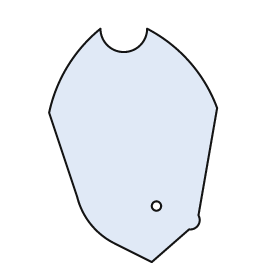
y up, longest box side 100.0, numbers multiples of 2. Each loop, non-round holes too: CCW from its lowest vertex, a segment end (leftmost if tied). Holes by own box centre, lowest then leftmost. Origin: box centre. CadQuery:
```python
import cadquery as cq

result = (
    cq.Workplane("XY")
    .moveTo(8.0, -50.0)
    .lineTo(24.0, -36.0)
    .threePointArc((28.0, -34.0), (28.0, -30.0))
    .lineTo(36.0, 16.0)
    .threePointArc((24.0, 36.0), (6.0, 50.0))
    .threePointArc((-4.0, 40.0), (-14.0, 50.0))
    .threePointArc((-28.0, 34.0), (-36.0, 14.0))
    .lineTo(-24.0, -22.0)
    .threePointArc((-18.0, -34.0), (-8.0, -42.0))
    .close()
    .moveTo(10.0, -26.0)
    .circle(2.0)
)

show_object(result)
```